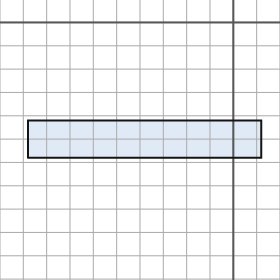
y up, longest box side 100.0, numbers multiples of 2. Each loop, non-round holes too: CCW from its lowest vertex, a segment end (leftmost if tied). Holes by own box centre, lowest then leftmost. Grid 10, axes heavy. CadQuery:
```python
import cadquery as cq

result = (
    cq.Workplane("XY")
    .moveTo(-88.0, -58.0)
    .lineTo(12.0, -58.0)
    .lineTo(12.0, -42.0)
    .lineTo(-88.0, -42.0)
    .close()
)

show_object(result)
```